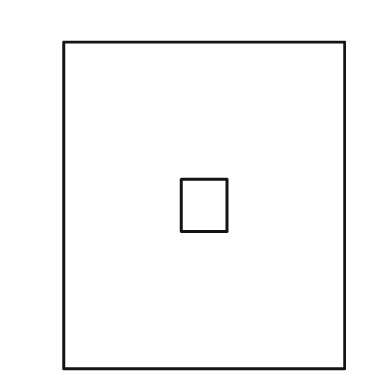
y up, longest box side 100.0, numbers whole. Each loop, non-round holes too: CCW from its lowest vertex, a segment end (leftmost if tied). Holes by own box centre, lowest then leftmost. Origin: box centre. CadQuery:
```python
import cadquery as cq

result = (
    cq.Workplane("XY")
    .moveTo(-43.0, -50.0)
    .lineTo(43.0, -50.0)
    .lineTo(43.0, 50.0)
    .lineTo(-43.0, 50.0)
    .close()
    .moveTo(-7.0, -8.0)
    .lineTo(7.0, -8.0)
    .lineTo(7.0, 8.0)
    .lineTo(-7.0, 8.0)
    .close()
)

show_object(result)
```